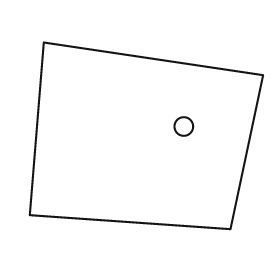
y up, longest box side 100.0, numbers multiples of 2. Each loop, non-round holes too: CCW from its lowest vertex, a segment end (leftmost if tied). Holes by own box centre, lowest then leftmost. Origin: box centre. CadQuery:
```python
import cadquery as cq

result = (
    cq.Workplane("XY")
    .moveTo(36.0, -40.0)
    .lineTo(50.0, 26.0)
    .lineTo(-44.0, 40.0)
    .lineTo(-50.0, -34.0)
    .close()
    .moveTo(16.0, 4.0)
    .circle(4.0)
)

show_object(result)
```